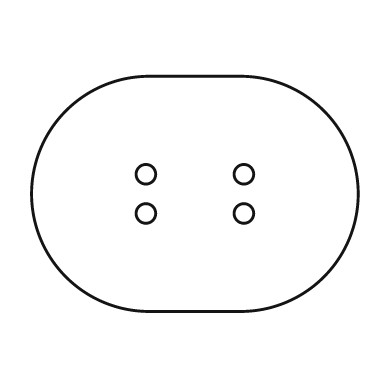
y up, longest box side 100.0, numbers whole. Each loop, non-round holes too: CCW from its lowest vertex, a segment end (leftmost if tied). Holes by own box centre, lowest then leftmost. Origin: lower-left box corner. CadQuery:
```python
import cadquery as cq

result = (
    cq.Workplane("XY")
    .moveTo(36.0, 0.0)
    .lineTo(64.0, 0.0)
    .threePointArc((100.0, 36.0), (64.0, 72.0))
    .lineTo(36.0, 72.0)
    .threePointArc((0.0, 36.0), (36.0, 0.0))
    .close()
    .moveTo(35.0, 30.0)
    .circle(3.0)
    .moveTo(65.0, 30.0)
    .circle(3.0)
    .moveTo(35.0, 42.0)
    .circle(3.0)
    .moveTo(65.0, 42.0)
    .circle(3.0)
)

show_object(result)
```